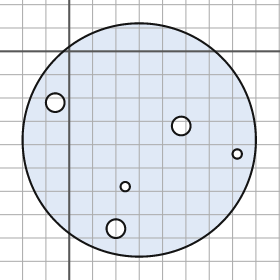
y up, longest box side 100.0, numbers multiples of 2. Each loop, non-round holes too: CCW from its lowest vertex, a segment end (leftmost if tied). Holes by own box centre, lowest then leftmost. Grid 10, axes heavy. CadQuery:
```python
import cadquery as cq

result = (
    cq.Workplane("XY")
    .moveTo(30.0, -38.0)
    .circle(50.0)
    .moveTo(20.0, -76.0)
    .circle(4.0)
    .moveTo(24.0, -58.0)
    .circle(2.0)
    .moveTo(72.0, -44.0)
    .circle(2.0)
    .moveTo(48.0, -32.0)
    .circle(4.0)
    .moveTo(-6.0, -22.0)
    .circle(4.0)
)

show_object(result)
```